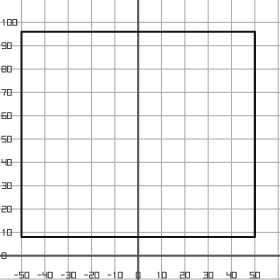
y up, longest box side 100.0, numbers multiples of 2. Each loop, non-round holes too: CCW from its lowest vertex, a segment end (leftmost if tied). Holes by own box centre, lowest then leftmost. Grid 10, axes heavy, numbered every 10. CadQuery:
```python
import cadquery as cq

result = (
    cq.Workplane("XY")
    .moveTo(-50.0, 8.0)
    .lineTo(50.0, 8.0)
    .lineTo(50.0, 96.0)
    .lineTo(-50.0, 96.0)
    .close()
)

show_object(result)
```